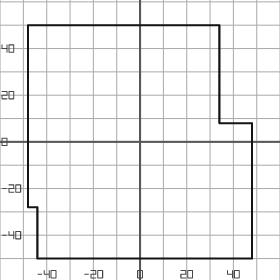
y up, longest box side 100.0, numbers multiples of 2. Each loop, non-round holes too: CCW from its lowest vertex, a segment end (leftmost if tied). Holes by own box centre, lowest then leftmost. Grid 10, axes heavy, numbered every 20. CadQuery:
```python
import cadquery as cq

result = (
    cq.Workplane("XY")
    .moveTo(-44.0, -50.0)
    .lineTo(48.0, -50.0)
    .lineTo(48.0, 8.0)
    .lineTo(34.0, 8.0)
    .lineTo(34.0, 50.0)
    .lineTo(-48.0, 50.0)
    .lineTo(-48.0, -28.0)
    .lineTo(-44.0, -28.0)
    .close()
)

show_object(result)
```